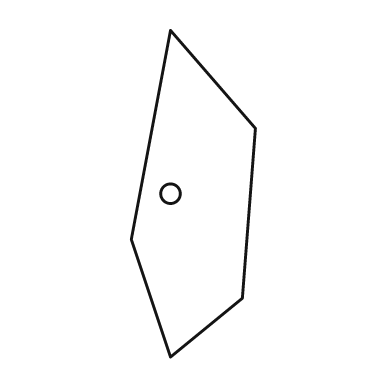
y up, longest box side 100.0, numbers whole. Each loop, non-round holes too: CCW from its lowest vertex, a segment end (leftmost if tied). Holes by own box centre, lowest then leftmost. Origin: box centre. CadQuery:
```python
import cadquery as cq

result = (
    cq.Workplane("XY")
    .moveTo(-7.0, -50.0)
    .lineTo(15.0, -32.0)
    .lineTo(19.0, 20.0)
    .lineTo(-7.0, 50.0)
    .lineTo(-19.0, -14.0)
    .close()
    .moveTo(-7.0, 0.0)
    .circle(3.0)
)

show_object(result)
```